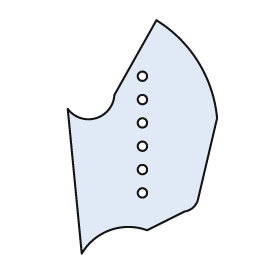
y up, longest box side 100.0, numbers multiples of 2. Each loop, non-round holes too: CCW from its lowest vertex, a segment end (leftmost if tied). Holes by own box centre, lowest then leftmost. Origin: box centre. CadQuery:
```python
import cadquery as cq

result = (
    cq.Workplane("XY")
    .moveTo(-26.0, -50.0)
    .threePointArc((-14.0, -40.0), (2.0, -40.0))
    .lineTo(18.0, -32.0)
    .threePointArc((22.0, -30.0), (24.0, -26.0))
    .lineTo(32.0, 8.0)
    .threePointArc((24.0, 32.0), (6.0, 50.0))
    .lineTo(-12.0, 18.0)
    .threePointArc((-20.0, 8.0), (-32.0, 12.0))
    .close()
    .moveTo(0.0, -24.0)
    .circle(2.0)
    .moveTo(0.0, -14.0)
    .circle(2.0)
    .moveTo(0.0, -4.0)
    .circle(2.0)
    .moveTo(0.0, 6.0)
    .circle(2.0)
    .moveTo(0.0, 16.0)
    .circle(2.0)
    .moveTo(0.0, 26.0)
    .circle(2.0)
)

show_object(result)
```